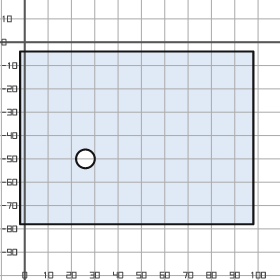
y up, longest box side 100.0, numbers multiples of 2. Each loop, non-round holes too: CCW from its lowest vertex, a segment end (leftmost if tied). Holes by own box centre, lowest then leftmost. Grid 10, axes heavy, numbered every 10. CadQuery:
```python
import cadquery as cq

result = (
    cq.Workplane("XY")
    .moveTo(-2.0, -78.0)
    .lineTo(98.0, -78.0)
    .lineTo(98.0, -4.0)
    .lineTo(-2.0, -4.0)
    .close()
    .moveTo(26.0, -50.0)
    .circle(4.0)
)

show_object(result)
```